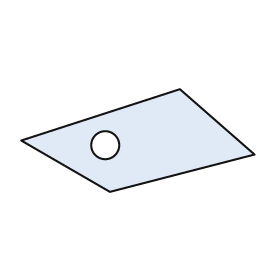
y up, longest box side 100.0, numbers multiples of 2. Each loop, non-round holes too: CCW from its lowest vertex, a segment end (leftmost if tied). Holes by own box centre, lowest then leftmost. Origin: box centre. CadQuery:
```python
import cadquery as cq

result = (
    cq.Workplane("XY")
    .moveTo(-12.0, -22.0)
    .lineTo(50.0, -6.0)
    .lineTo(18.0, 22.0)
    .lineTo(-50.0, 0.0)
    .close()
    .moveTo(-14.0, -2.0)
    .circle(6.0)
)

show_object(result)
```